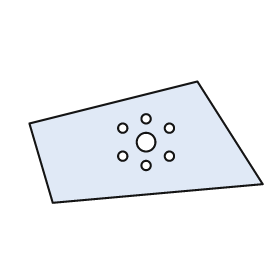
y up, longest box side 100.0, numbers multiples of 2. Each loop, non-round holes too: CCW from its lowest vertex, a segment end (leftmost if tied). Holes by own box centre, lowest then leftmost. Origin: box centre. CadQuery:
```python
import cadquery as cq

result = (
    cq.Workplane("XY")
    .moveTo(-40.0, -26.0)
    .lineTo(50.0, -18.0)
    .lineTo(22.0, 26.0)
    .lineTo(-50.0, 8.0)
    .close()
    .moveTo(0.0, -10.0)
    .circle(2.0)
    .moveTo(-10.0, -6.0)
    .circle(2.0)
    .moveTo(10.0, -6.0)
    .circle(2.0)
    .moveTo(0.0, 0.0)
    .circle(4.0)
    .moveTo(-10.0, 6.0)
    .circle(2.0)
    .moveTo(10.0, 6.0)
    .circle(2.0)
    .moveTo(0.0, 10.0)
    .circle(2.0)
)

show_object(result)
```